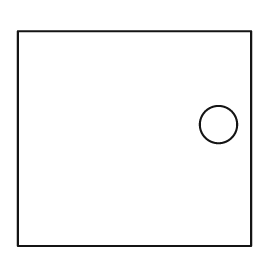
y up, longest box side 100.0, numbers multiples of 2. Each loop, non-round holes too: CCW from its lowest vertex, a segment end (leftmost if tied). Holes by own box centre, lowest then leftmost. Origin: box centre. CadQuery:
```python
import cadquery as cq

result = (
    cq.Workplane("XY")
    .moveTo(-50.0, -46.0)
    .lineTo(50.0, -46.0)
    .lineTo(50.0, 46.0)
    .lineTo(-50.0, 46.0)
    .close()
    .moveTo(36.0, 6.0)
    .circle(8.0)
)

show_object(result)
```